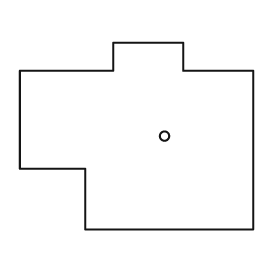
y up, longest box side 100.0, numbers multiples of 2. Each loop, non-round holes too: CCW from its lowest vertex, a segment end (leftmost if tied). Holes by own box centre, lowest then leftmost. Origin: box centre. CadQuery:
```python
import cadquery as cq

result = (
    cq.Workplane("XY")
    .moveTo(-22.0, -40.0)
    .lineTo(50.0, -40.0)
    .lineTo(50.0, 28.0)
    .lineTo(20.0, 28.0)
    .lineTo(20.0, 40.0)
    .lineTo(-10.0, 40.0)
    .lineTo(-10.0, 28.0)
    .lineTo(-50.0, 28.0)
    .lineTo(-50.0, -14.0)
    .lineTo(-22.0, -14.0)
    .close()
    .moveTo(12.0, 0.0)
    .circle(2.0)
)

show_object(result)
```